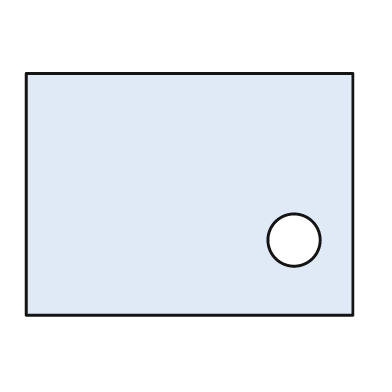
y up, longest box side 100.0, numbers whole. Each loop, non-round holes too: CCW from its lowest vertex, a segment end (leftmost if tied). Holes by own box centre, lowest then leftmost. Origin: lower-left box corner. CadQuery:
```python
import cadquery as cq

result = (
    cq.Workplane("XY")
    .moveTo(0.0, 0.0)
    .lineTo(100.0, 0.0)
    .lineTo(100.0, 74.0)
    .lineTo(0.0, 74.0)
    .close()
    .moveTo(82.0, 23.0)
    .circle(8.0)
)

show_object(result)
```